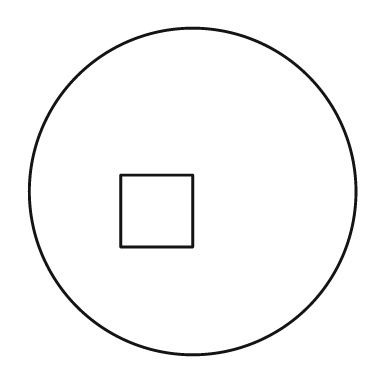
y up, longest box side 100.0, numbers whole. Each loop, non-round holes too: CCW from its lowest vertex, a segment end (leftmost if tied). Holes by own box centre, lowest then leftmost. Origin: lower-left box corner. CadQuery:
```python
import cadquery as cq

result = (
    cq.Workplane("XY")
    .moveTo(50.0, 50.0)
    .circle(50.0)
    .moveTo(28.0, 33.0)
    .lineTo(50.0, 33.0)
    .lineTo(50.0, 55.0)
    .lineTo(28.0, 55.0)
    .close()
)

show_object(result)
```